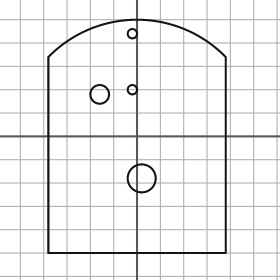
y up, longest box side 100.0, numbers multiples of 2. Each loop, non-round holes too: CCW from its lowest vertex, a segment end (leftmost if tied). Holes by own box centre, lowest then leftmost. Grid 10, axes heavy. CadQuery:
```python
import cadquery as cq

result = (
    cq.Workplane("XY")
    .moveTo(-38.0, -50.0)
    .lineTo(38.0, -50.0)
    .lineTo(38.0, 34.0)
    .threePointArc((0.0, 50.0), (-38.0, 34.0))
    .close()
    .moveTo(2.0, -18.0)
    .circle(6.0)
    .moveTo(-16.0, 18.0)
    .circle(4.0)
    .moveTo(-2.0, 20.0)
    .circle(2.0)
    .moveTo(-2.0, 44.0)
    .circle(2.0)
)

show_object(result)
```